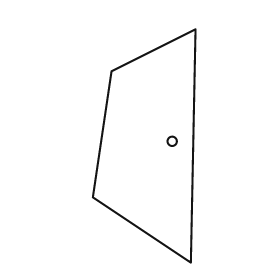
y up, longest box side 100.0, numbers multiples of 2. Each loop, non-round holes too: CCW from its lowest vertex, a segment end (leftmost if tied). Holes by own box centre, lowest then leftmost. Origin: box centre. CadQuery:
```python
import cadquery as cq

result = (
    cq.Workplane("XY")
    .moveTo(20.0, -50.0)
    .lineTo(22.0, 50.0)
    .lineTo(-14.0, 32.0)
    .lineTo(-22.0, -22.0)
    .close()
    .moveTo(12.0, 2.0)
    .circle(2.0)
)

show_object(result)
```